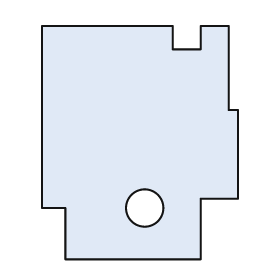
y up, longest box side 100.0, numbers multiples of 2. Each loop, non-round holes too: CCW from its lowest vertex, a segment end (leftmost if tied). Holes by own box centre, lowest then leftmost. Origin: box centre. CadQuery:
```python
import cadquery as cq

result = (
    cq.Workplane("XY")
    .moveTo(-32.0, -50.0)
    .lineTo(26.0, -50.0)
    .lineTo(26.0, -24.0)
    .lineTo(42.0, -24.0)
    .lineTo(42.0, 14.0)
    .lineTo(38.0, 14.0)
    .lineTo(38.0, 50.0)
    .lineTo(26.0, 50.0)
    .lineTo(26.0, 40.0)
    .lineTo(14.0, 40.0)
    .lineTo(14.0, 50.0)
    .lineTo(-42.0, 50.0)
    .lineTo(-42.0, -28.0)
    .lineTo(-32.0, -28.0)
    .close()
    .moveTo(2.0, -28.0)
    .circle(8.0)
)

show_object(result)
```